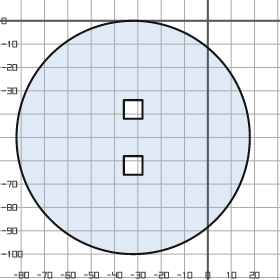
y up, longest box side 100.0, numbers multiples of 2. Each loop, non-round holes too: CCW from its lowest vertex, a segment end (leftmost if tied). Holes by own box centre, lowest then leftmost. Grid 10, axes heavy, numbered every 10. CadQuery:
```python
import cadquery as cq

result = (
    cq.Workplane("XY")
    .moveTo(-32.0, -50.0)
    .circle(50.0)
    .moveTo(-36.0, -66.0)
    .lineTo(-28.0, -66.0)
    .lineTo(-28.0, -58.0)
    .lineTo(-36.0, -58.0)
    .close()
    .moveTo(-36.0, -42.0)
    .lineTo(-28.0, -42.0)
    .lineTo(-28.0, -34.0)
    .lineTo(-36.0, -34.0)
    .close()
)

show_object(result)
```